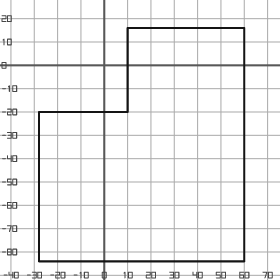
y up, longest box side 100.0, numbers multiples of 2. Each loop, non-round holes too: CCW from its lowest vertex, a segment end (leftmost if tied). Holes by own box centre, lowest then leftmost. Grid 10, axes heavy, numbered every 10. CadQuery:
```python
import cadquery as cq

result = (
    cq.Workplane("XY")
    .moveTo(-28.0, -84.0)
    .lineTo(60.0, -84.0)
    .lineTo(60.0, 16.0)
    .lineTo(10.0, 16.0)
    .lineTo(10.0, -20.0)
    .lineTo(-28.0, -20.0)
    .close()
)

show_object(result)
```